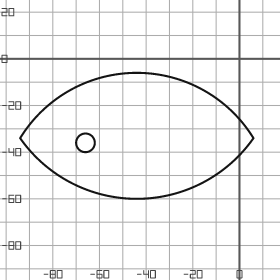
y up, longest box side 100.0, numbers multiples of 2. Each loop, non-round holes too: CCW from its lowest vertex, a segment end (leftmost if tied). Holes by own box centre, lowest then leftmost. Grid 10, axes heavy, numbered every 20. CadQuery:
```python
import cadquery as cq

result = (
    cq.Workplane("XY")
    .moveTo(-94.0, -34.0)
    .threePointArc((-44.0, -60.0), (6.0, -34.0))
    .threePointArc((-44.0, -6.0), (-94.0, -34.0))
    .close()
    .moveTo(-66.0, -36.0)
    .circle(4.0)
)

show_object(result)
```